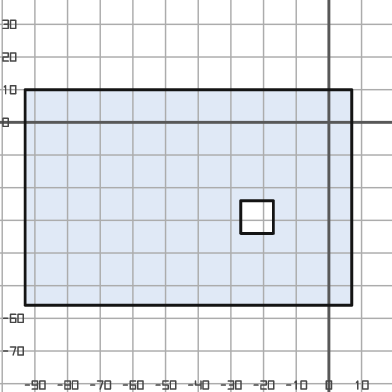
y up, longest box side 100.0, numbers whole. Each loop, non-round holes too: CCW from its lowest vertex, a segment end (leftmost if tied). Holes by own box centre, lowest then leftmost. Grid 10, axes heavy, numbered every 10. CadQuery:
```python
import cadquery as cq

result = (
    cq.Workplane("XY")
    .moveTo(-93.0, -56.0)
    .lineTo(7.0, -56.0)
    .lineTo(7.0, 10.0)
    .lineTo(-93.0, 10.0)
    .close()
    .moveTo(-27.0, -34.0)
    .lineTo(-17.0, -34.0)
    .lineTo(-17.0, -24.0)
    .lineTo(-27.0, -24.0)
    .close()
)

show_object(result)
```